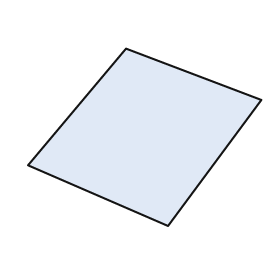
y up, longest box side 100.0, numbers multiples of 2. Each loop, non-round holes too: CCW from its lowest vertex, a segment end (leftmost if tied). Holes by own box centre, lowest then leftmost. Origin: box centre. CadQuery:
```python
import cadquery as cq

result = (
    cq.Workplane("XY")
    .moveTo(10.0, -38.0)
    .lineTo(50.0, 16.0)
    .lineTo(-8.0, 38.0)
    .lineTo(-50.0, -12.0)
    .close()
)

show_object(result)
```